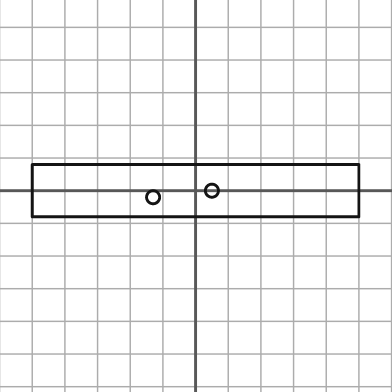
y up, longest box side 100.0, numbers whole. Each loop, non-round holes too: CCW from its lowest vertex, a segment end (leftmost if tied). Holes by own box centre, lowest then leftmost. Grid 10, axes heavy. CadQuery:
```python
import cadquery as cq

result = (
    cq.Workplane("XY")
    .moveTo(-50.0, -8.0)
    .lineTo(50.0, -8.0)
    .lineTo(50.0, 8.0)
    .lineTo(-50.0, 8.0)
    .close()
    .moveTo(-13.0, -2.0)
    .circle(2.0)
    .moveTo(5.0, 0.0)
    .circle(2.0)
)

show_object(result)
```